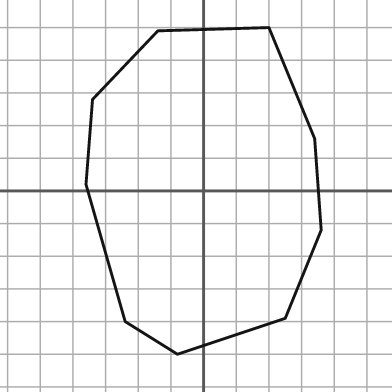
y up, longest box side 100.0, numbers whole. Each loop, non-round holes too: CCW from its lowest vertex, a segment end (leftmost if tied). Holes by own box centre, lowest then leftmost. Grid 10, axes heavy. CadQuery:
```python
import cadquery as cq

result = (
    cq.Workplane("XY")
    .moveTo(-8.0, -50.0)
    .lineTo(25.0, -39.0)
    .lineTo(36.0, -12.0)
    .lineTo(34.0, 16.0)
    .lineTo(20.0, 50.0)
    .lineTo(-14.0, 49.0)
    .lineTo(-34.0, 28.0)
    .lineTo(-36.0, 2.0)
    .lineTo(-24.0, -40.0)
    .close()
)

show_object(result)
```